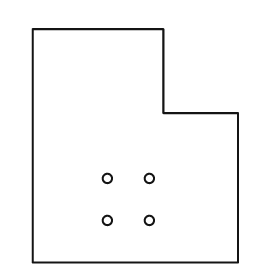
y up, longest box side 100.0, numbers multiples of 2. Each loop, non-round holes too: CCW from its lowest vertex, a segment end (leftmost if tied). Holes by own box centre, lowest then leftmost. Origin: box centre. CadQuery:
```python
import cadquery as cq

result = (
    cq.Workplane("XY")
    .moveTo(-44.0, -50.0)
    .lineTo(44.0, -50.0)
    .lineTo(44.0, 14.0)
    .lineTo(12.0, 14.0)
    .lineTo(12.0, 50.0)
    .lineTo(-44.0, 50.0)
    .close()
    .moveTo(-12.0, -32.0)
    .circle(2.0)
    .moveTo(6.0, -32.0)
    .circle(2.0)
    .moveTo(-12.0, -14.0)
    .circle(2.0)
    .moveTo(6.0, -14.0)
    .circle(2.0)
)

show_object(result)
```